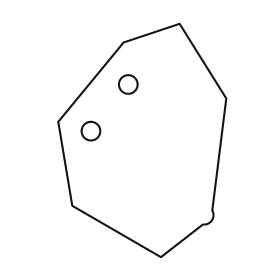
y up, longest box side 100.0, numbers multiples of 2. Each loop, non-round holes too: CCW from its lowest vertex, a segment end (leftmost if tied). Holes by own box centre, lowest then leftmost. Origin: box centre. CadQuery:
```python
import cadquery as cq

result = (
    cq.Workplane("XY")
    .moveTo(8.0, -50.0)
    .lineTo(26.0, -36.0)
    .threePointArc((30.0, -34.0), (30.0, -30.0))
    .lineTo(36.0, 18.0)
    .lineTo(16.0, 50.0)
    .lineTo(-8.0, 42.0)
    .lineTo(-36.0, 8.0)
    .lineTo(-30.0, -28.0)
    .close()
    .moveTo(-22.0, 4.0)
    .circle(4.0)
    .moveTo(-6.0, 24.0)
    .circle(4.0)
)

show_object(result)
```